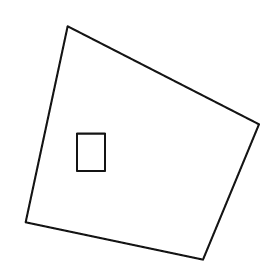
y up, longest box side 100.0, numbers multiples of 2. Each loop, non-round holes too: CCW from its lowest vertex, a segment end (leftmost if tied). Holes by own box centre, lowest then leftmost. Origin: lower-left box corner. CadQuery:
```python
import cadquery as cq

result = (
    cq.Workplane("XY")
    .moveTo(76.0, 0.0)
    .lineTo(100.0, 58.0)
    .lineTo(18.0, 100.0)
    .lineTo(0.0, 16.0)
    .close()
    .moveTo(22.0, 38.0)
    .lineTo(34.0, 38.0)
    .lineTo(34.0, 54.0)
    .lineTo(22.0, 54.0)
    .close()
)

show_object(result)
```